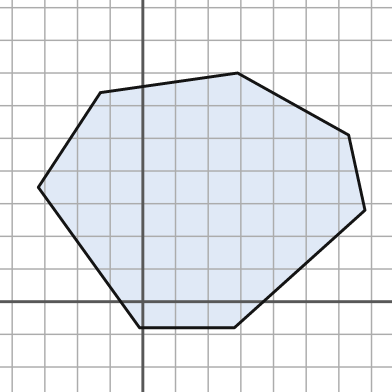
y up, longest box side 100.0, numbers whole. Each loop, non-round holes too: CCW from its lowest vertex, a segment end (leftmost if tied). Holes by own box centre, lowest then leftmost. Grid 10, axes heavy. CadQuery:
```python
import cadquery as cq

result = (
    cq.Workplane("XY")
    .moveTo(-1.0, -8.0)
    .lineTo(28.0, -8.0)
    .lineTo(68.0, 28.0)
    .lineTo(63.0, 51.0)
    .lineTo(29.0, 70.0)
    .lineTo(-13.0, 64.0)
    .lineTo(-32.0, 35.0)
    .close()
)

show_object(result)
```